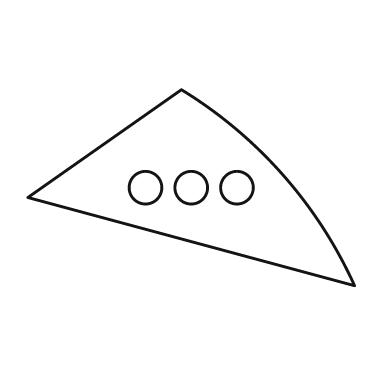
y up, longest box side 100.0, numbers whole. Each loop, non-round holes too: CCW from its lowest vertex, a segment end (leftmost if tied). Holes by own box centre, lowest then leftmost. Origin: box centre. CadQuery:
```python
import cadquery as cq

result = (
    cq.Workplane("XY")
    .moveTo(50.0, -30.0)
    .threePointArc((28.0, 4.0), (-3.0, 30.0))
    .lineTo(-50.0, -3.0)
    .close()
    .moveTo(-14.0, 0.0)
    .circle(5.0)
    .moveTo(0.0, 0.0)
    .circle(5.0)
    .moveTo(14.0, 0.0)
    .circle(5.0)
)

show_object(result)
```